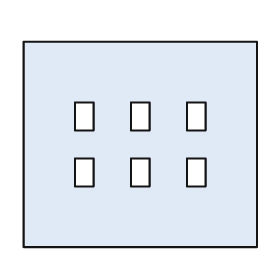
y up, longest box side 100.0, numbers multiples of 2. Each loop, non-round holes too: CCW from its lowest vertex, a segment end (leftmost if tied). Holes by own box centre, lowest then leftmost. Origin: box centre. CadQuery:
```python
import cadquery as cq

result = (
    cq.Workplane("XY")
    .moveTo(-50.0, -44.0)
    .lineTo(50.0, -44.0)
    .lineTo(50.0, 44.0)
    .lineTo(-50.0, 44.0)
    .close()
    .moveTo(-28.0, -18.0)
    .lineTo(-20.0, -18.0)
    .lineTo(-20.0, -6.0)
    .lineTo(-28.0, -6.0)
    .close()
    .moveTo(-4.0, -18.0)
    .lineTo(4.0, -18.0)
    .lineTo(4.0, -6.0)
    .lineTo(-4.0, -6.0)
    .close()
    .moveTo(20.0, -18.0)
    .lineTo(28.0, -18.0)
    .lineTo(28.0, -6.0)
    .lineTo(20.0, -6.0)
    .close()
    .moveTo(-28.0, 6.0)
    .lineTo(-20.0, 6.0)
    .lineTo(-20.0, 18.0)
    .lineTo(-28.0, 18.0)
    .close()
    .moveTo(-4.0, 6.0)
    .lineTo(4.0, 6.0)
    .lineTo(4.0, 18.0)
    .lineTo(-4.0, 18.0)
    .close()
    .moveTo(20.0, 6.0)
    .lineTo(28.0, 6.0)
    .lineTo(28.0, 18.0)
    .lineTo(20.0, 18.0)
    .close()
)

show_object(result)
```